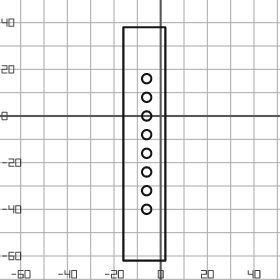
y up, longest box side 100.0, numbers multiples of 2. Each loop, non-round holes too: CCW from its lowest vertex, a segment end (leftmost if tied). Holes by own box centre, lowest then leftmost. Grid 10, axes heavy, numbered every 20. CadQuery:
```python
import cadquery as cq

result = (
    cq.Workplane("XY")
    .moveTo(-16.0, -62.0)
    .lineTo(2.0, -62.0)
    .lineTo(2.0, 38.0)
    .lineTo(-16.0, 38.0)
    .close()
    .moveTo(-6.0, -40.0)
    .circle(2.0)
    .moveTo(-6.0, -32.0)
    .circle(2.0)
    .moveTo(-6.0, -24.0)
    .circle(2.0)
    .moveTo(-6.0, -16.0)
    .circle(2.0)
    .moveTo(-6.0, -8.0)
    .circle(2.0)
    .moveTo(-6.0, 0.0)
    .circle(2.0)
    .moveTo(-6.0, 8.0)
    .circle(2.0)
    .moveTo(-6.0, 16.0)
    .circle(2.0)
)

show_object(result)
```